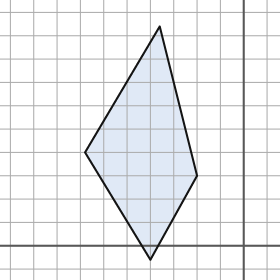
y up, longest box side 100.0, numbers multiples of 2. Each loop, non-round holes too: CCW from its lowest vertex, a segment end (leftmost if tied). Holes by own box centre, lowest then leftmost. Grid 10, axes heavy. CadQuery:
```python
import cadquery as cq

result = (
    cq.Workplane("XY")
    .moveTo(-40.0, -6.0)
    .lineTo(-20.0, 30.0)
    .lineTo(-36.0, 94.0)
    .lineTo(-68.0, 40.0)
    .close()
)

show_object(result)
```